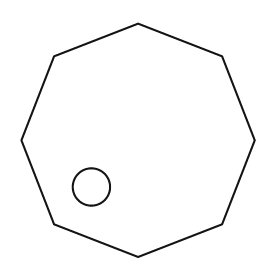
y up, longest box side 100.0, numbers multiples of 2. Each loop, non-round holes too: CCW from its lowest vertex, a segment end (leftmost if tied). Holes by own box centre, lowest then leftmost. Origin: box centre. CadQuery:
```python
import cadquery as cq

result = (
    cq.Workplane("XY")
    .moveTo(0.0, -50.0)
    .lineTo(36.0, -36.0)
    .lineTo(50.0, 0.0)
    .lineTo(36.0, 36.0)
    .lineTo(0.0, 50.0)
    .lineTo(-36.0, 36.0)
    .lineTo(-50.0, 0.0)
    .lineTo(-36.0, -36.0)
    .close()
    .moveTo(-20.0, -20.0)
    .circle(8.0)
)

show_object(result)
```